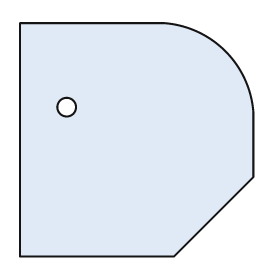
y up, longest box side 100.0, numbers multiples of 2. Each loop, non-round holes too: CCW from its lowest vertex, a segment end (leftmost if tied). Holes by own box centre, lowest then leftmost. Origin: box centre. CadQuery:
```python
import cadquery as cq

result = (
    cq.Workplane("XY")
    .moveTo(-50.0, -50.0)
    .lineTo(16.0, -50.0)
    .lineTo(50.0, -16.0)
    .lineTo(50.0, 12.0)
    .threePointArc((38.0, 38.0), (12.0, 50.0))
    .lineTo(-50.0, 50.0)
    .close()
    .moveTo(-30.0, 14.0)
    .circle(4.0)
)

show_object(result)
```